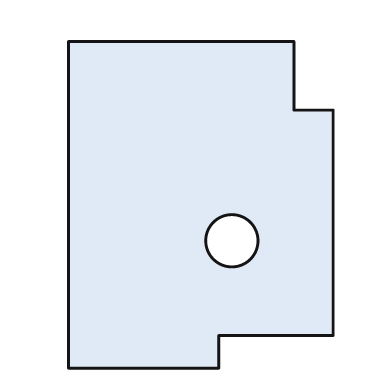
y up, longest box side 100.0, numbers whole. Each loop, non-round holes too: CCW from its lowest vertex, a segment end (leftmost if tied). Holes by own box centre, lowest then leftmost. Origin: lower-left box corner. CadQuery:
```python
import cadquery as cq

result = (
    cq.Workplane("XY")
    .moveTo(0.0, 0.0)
    .lineTo(46.0, 0.0)
    .lineTo(46.0, 10.0)
    .lineTo(81.0, 10.0)
    .lineTo(81.0, 79.0)
    .lineTo(69.0, 79.0)
    .lineTo(69.0, 100.0)
    .lineTo(0.0, 100.0)
    .close()
    .moveTo(50.0, 39.0)
    .circle(8.0)
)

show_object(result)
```